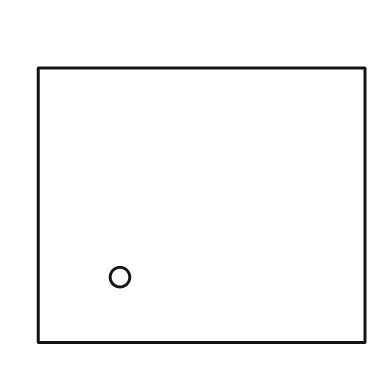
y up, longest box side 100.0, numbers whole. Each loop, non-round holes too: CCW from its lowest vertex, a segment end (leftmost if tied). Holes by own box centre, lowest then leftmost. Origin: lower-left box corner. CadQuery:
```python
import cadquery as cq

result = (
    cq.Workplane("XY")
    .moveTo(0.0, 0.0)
    .lineTo(100.0, 0.0)
    .lineTo(100.0, 84.0)
    .lineTo(0.0, 84.0)
    .close()
    .moveTo(25.0, 20.0)
    .circle(3.0)
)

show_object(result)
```